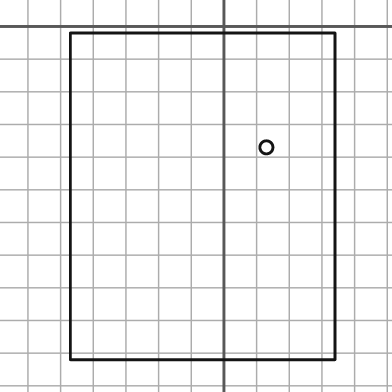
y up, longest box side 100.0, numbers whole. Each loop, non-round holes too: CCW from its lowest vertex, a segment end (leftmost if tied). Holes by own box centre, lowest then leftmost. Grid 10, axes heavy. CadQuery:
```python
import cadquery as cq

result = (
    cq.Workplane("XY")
    .moveTo(-47.0, -102.0)
    .lineTo(34.0, -102.0)
    .lineTo(34.0, -2.0)
    .lineTo(-47.0, -2.0)
    .close()
    .moveTo(13.0, -37.0)
    .circle(2.0)
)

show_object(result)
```